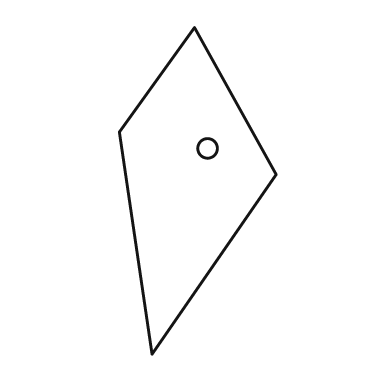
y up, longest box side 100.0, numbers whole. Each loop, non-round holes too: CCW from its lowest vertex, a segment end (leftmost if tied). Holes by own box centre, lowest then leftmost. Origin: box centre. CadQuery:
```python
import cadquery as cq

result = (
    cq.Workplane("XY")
    .moveTo(-14.0, -50.0)
    .lineTo(24.0, 5.0)
    .lineTo(-1.0, 50.0)
    .lineTo(-24.0, 18.0)
    .close()
    .moveTo(3.0, 13.0)
    .circle(3.0)
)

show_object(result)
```